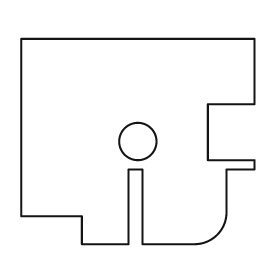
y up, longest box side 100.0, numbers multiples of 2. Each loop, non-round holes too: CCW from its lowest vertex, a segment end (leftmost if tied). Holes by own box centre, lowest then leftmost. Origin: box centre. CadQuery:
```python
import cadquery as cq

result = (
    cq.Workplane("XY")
    .moveTo(-24.0, -44.0)
    .lineTo(-4.0, -44.0)
    .lineTo(-4.0, -12.0)
    .lineTo(2.0, -12.0)
    .lineTo(2.0, -44.0)
    .lineTo(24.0, -44.0)
    .threePointArc((34.0, -40.0), (38.0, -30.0))
    .lineTo(38.0, -12.0)
    .lineTo(50.0, -12.0)
    .lineTo(50.0, -8.0)
    .lineTo(30.0, -8.0)
    .lineTo(30.0, 16.0)
    .lineTo(50.0, 16.0)
    .lineTo(50.0, 44.0)
    .lineTo(-50.0, 44.0)
    .lineTo(-50.0, -32.0)
    .lineTo(-24.0, -32.0)
    .close()
    .moveTo(0.0, 0.0)
    .circle(8.0)
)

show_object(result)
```